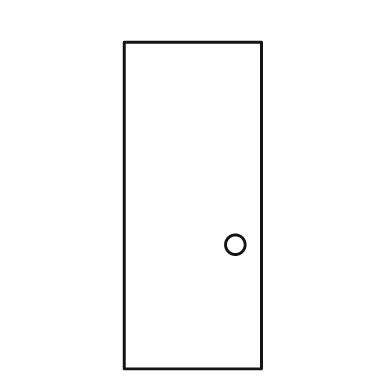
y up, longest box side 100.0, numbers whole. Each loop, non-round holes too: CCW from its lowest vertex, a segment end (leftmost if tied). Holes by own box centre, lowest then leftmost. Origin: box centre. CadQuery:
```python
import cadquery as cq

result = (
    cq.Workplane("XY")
    .moveTo(-21.0, -50.0)
    .lineTo(21.0, -50.0)
    .lineTo(21.0, 50.0)
    .lineTo(-21.0, 50.0)
    .close()
    .moveTo(13.0, -12.0)
    .circle(3.0)
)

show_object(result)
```